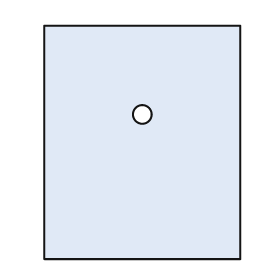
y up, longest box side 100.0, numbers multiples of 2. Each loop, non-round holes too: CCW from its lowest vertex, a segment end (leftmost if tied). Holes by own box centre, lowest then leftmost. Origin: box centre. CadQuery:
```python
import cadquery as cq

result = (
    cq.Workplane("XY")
    .moveTo(-42.0, -50.0)
    .lineTo(42.0, -50.0)
    .lineTo(42.0, 50.0)
    .lineTo(-42.0, 50.0)
    .close()
    .moveTo(0.0, 12.0)
    .circle(4.0)
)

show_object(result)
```